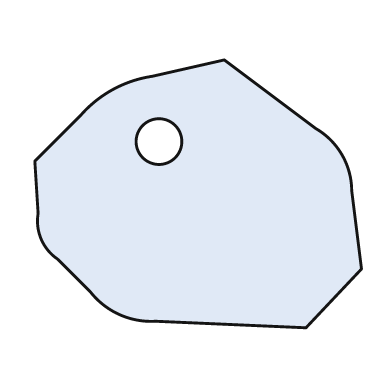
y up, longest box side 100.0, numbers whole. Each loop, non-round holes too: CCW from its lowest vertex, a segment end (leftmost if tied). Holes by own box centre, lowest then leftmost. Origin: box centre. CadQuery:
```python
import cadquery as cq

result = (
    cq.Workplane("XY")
    .moveTo(33.0, -41.0)
    .lineTo(50.0, -23.0)
    .lineTo(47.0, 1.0)
    .threePointArc((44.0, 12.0), (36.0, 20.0))
    .lineTo(8.0, 41.0)
    .lineTo(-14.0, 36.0)
    .threePointArc((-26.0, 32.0), (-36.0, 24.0))
    .lineTo(-50.0, 10.0)
    .lineTo(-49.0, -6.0)
    .threePointArc((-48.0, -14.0), (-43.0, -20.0))
    .lineTo(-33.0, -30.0)
    .threePointArc((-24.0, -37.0), (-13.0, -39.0))
    .close()
    .moveTo(-12.0, 16.0)
    .circle(7.0)
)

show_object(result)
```